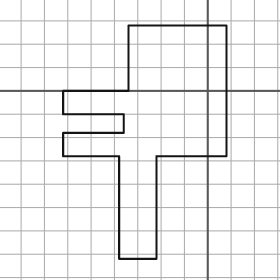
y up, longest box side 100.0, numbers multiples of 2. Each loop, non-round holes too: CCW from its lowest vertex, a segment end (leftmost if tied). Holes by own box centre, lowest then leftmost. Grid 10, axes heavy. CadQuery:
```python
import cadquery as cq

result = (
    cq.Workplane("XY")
    .moveTo(-38.0, -72.0)
    .lineTo(-22.0, -72.0)
    .lineTo(-22.0, -28.0)
    .lineTo(8.0, -28.0)
    .lineTo(8.0, 28.0)
    .lineTo(-34.0, 28.0)
    .lineTo(-34.0, 0.0)
    .lineTo(-62.0, 0.0)
    .lineTo(-62.0, -10.0)
    .lineTo(-36.0, -10.0)
    .lineTo(-36.0, -18.0)
    .lineTo(-62.0, -18.0)
    .lineTo(-62.0, -28.0)
    .lineTo(-38.0, -28.0)
    .close()
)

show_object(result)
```